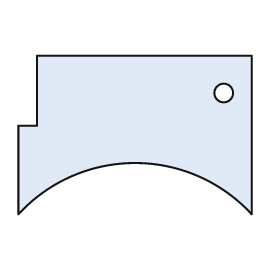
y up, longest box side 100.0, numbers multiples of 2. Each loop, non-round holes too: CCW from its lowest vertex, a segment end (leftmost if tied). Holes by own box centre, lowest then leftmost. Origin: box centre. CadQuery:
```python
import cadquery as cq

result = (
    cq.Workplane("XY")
    .moveTo(-50.0, -34.0)
    .threePointArc((0.0, -12.0), (50.0, -34.0))
    .lineTo(50.0, 34.0)
    .lineTo(-42.0, 34.0)
    .lineTo(-42.0, 4.0)
    .lineTo(-50.0, 4.0)
    .close()
    .moveTo(38.0, 18.0)
    .circle(4.0)
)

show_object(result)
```